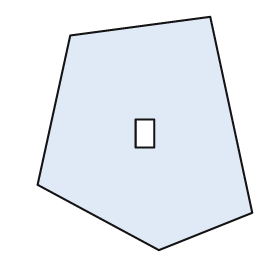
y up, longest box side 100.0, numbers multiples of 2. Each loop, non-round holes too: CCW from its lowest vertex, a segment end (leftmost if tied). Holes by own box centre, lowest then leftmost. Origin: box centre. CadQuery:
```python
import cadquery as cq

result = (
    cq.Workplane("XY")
    .moveTo(6.0, -50.0)
    .lineTo(46.0, -34.0)
    .lineTo(28.0, 50.0)
    .lineTo(-32.0, 42.0)
    .lineTo(-46.0, -22.0)
    .close()
    .moveTo(-4.0, -6.0)
    .lineTo(4.0, -6.0)
    .lineTo(4.0, 6.0)
    .lineTo(-4.0, 6.0)
    .close()
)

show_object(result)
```